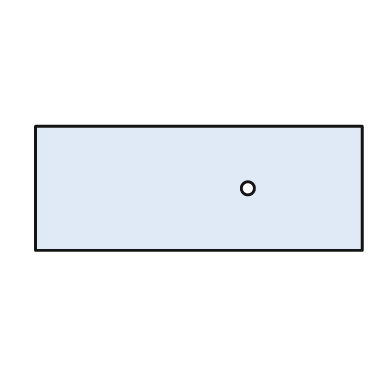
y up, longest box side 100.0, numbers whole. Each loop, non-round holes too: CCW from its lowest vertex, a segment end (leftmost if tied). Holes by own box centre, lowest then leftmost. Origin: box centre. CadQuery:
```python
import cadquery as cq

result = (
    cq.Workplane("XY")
    .moveTo(-50.0, -19.0)
    .lineTo(50.0, -19.0)
    .lineTo(50.0, 19.0)
    .lineTo(-50.0, 19.0)
    .close()
    .moveTo(15.0, 0.0)
    .circle(2.0)
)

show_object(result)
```